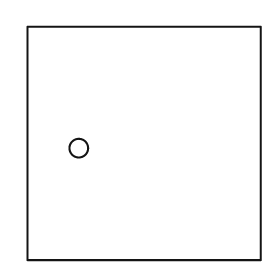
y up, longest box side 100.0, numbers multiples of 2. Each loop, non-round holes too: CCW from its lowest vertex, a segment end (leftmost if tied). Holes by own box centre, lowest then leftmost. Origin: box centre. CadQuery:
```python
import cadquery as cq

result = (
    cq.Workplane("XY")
    .moveTo(-50.0, -50.0)
    .lineTo(50.0, -50.0)
    .lineTo(50.0, 50.0)
    .lineTo(-50.0, 50.0)
    .close()
    .moveTo(-28.0, -2.0)
    .circle(4.0)
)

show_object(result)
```